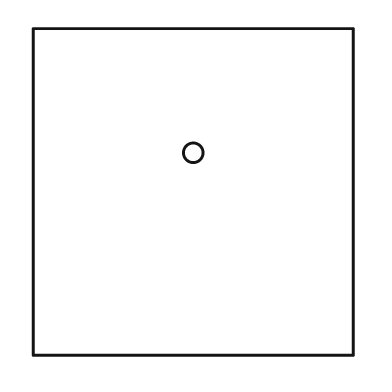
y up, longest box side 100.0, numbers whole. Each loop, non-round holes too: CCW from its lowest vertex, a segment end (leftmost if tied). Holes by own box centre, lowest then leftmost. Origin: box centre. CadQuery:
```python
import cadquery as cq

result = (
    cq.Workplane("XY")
    .moveTo(-49.0, -50.0)
    .lineTo(49.0, -50.0)
    .lineTo(49.0, 50.0)
    .lineTo(-49.0, 50.0)
    .close()
    .moveTo(0.0, 12.0)
    .circle(3.0)
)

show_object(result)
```